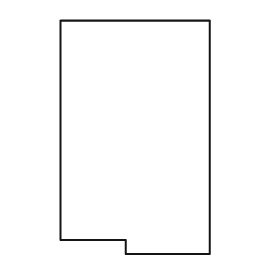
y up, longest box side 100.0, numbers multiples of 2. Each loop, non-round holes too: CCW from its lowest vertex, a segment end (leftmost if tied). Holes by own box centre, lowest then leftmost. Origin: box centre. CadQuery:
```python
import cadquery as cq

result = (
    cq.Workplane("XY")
    .moveTo(-4.0, -50.0)
    .lineTo(32.0, -50.0)
    .lineTo(32.0, 50.0)
    .lineTo(-32.0, 50.0)
    .lineTo(-32.0, -44.0)
    .lineTo(-4.0, -44.0)
    .close()
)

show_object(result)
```